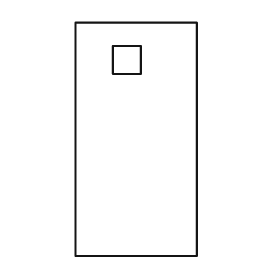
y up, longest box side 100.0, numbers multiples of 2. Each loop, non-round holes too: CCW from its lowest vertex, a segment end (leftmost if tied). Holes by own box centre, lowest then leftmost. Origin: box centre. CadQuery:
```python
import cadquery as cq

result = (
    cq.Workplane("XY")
    .moveTo(-26.0, -50.0)
    .lineTo(26.0, -50.0)
    .lineTo(26.0, 50.0)
    .lineTo(-26.0, 50.0)
    .close()
    .moveTo(-10.0, 28.0)
    .lineTo(2.0, 28.0)
    .lineTo(2.0, 40.0)
    .lineTo(-10.0, 40.0)
    .close()
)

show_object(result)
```